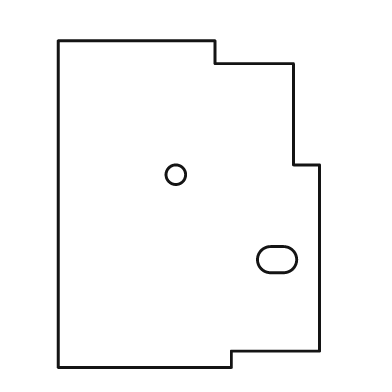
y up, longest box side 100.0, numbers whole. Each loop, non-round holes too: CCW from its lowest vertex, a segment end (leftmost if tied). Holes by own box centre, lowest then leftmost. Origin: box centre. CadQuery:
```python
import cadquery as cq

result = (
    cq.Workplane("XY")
    .moveTo(-40.0, -50.0)
    .lineTo(13.0, -50.0)
    .lineTo(13.0, -45.0)
    .lineTo(40.0, -45.0)
    .lineTo(40.0, 12.0)
    .lineTo(32.0, 12.0)
    .lineTo(32.0, 43.0)
    .lineTo(8.0, 43.0)
    .lineTo(8.0, 50.0)
    .lineTo(-40.0, 50.0)
    .close()
    .moveTo(25.0, -21.0)
    .lineTo(29.0, -21.0)
    .threePointArc((33.0, -17.0), (29.0, -13.0))
    .lineTo(25.0, -13.0)
    .threePointArc((21.0, -17.0), (25.0, -21.0))
    .close()
    .moveTo(-4.0, 9.0)
    .circle(3.0)
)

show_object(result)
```